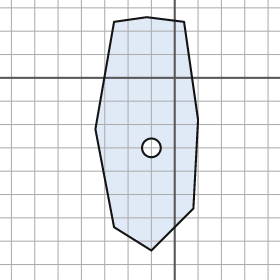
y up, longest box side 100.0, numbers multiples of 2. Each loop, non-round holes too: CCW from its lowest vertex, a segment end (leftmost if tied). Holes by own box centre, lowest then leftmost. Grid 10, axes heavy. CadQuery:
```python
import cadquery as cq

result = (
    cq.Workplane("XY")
    .moveTo(-10.0, -74.0)
    .lineTo(8.0, -56.0)
    .lineTo(10.0, -18.0)
    .lineTo(4.0, 24.0)
    .lineTo(-12.0, 26.0)
    .lineTo(-26.0, 24.0)
    .lineTo(-34.0, -22.0)
    .lineTo(-26.0, -64.0)
    .close()
    .moveTo(-10.0, -30.0)
    .circle(4.0)
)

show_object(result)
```